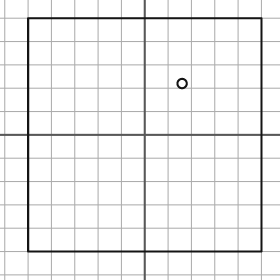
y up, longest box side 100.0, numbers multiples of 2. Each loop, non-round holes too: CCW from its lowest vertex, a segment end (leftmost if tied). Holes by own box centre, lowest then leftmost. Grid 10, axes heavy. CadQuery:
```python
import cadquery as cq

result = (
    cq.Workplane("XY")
    .moveTo(-50.0, -50.0)
    .lineTo(50.0, -50.0)
    .lineTo(50.0, 50.0)
    .lineTo(-50.0, 50.0)
    .close()
    .moveTo(16.0, 22.0)
    .circle(2.0)
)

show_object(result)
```